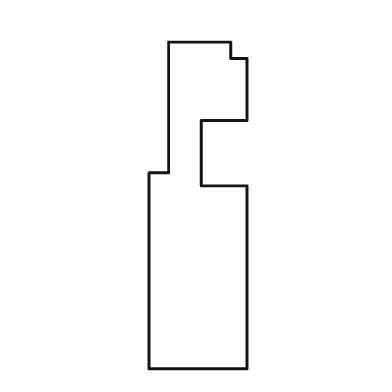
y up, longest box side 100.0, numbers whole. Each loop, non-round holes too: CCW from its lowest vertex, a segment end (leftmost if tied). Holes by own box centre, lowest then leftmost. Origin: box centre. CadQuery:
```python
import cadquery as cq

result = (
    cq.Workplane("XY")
    .moveTo(-15.0, -50.0)
    .lineTo(15.0, -50.0)
    .lineTo(15.0, 6.0)
    .lineTo(1.0, 6.0)
    .lineTo(1.0, 26.0)
    .lineTo(15.0, 26.0)
    .lineTo(15.0, 45.0)
    .lineTo(10.0, 45.0)
    .lineTo(10.0, 50.0)
    .lineTo(-9.0, 50.0)
    .lineTo(-9.0, 10.0)
    .lineTo(-15.0, 10.0)
    .close()
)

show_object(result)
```